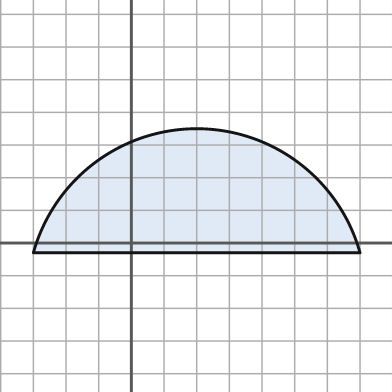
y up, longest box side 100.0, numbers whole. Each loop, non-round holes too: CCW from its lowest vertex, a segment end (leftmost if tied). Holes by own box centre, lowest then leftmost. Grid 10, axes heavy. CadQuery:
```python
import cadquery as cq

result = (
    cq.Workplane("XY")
    .moveTo(-30.0, -3.0)
    .lineTo(70.0, -3.0)
    .threePointArc((20.0, 35.0), (-30.0, -3.0))
    .close()
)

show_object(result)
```